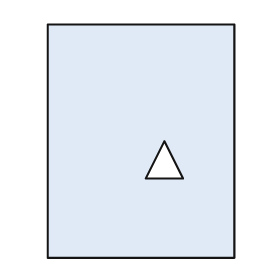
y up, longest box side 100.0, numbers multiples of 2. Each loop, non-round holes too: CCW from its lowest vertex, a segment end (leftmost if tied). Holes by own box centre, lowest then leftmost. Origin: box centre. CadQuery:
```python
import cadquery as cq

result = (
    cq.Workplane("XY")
    .moveTo(-40.0, -50.0)
    .lineTo(40.0, -50.0)
    .lineTo(40.0, 50.0)
    .lineTo(-40.0, 50.0)
    .close()
    .moveTo(2.0, -16.0)
    .lineTo(18.0, -16.0)
    .lineTo(10.0, 0.0)
    .close()
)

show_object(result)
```